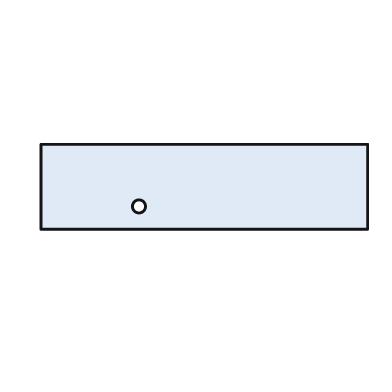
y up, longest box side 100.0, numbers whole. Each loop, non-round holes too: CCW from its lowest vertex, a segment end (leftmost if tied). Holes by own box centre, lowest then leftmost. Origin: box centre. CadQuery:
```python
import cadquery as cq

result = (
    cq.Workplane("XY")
    .moveTo(-50.0, -13.0)
    .lineTo(50.0, -13.0)
    .lineTo(50.0, 13.0)
    .lineTo(-50.0, 13.0)
    .close()
    .moveTo(-20.0, -6.0)
    .circle(2.0)
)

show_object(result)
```